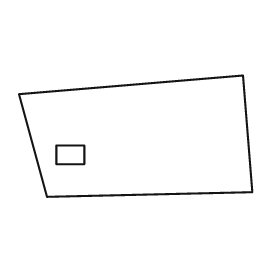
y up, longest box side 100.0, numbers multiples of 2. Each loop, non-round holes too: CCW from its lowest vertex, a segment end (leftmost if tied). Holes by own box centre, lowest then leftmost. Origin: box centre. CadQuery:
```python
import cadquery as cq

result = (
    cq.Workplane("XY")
    .moveTo(-38.0, -26.0)
    .lineTo(50.0, -24.0)
    .lineTo(46.0, 26.0)
    .lineTo(-50.0, 18.0)
    .close()
    .moveTo(-34.0, -12.0)
    .lineTo(-22.0, -12.0)
    .lineTo(-22.0, -4.0)
    .lineTo(-34.0, -4.0)
    .close()
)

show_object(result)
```